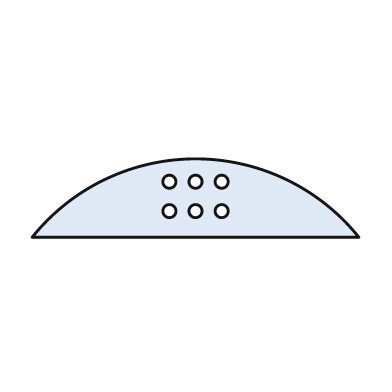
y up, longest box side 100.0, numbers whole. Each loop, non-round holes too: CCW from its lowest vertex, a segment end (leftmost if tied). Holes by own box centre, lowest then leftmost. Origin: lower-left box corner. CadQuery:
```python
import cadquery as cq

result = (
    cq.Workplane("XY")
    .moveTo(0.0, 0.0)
    .lineTo(100.0, 0.0)
    .threePointArc((50.0, 24.0), (0.0, 0.0))
    .close()
    .moveTo(42.0, 8.0)
    .circle(2.0)
    .moveTo(50.0, 8.0)
    .circle(2.0)
    .moveTo(58.0, 8.0)
    .circle(2.0)
    .moveTo(42.0, 17.0)
    .circle(2.0)
    .moveTo(50.0, 17.0)
    .circle(2.0)
    .moveTo(58.0, 17.0)
    .circle(2.0)
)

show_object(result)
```